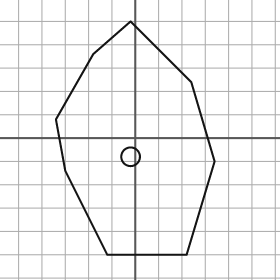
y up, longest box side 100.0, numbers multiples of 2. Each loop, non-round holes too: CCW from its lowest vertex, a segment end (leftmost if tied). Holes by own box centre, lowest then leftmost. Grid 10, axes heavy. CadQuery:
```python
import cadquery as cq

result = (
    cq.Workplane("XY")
    .moveTo(-12.0, -50.0)
    .lineTo(22.0, -50.0)
    .lineTo(34.0, -10.0)
    .lineTo(24.0, 24.0)
    .lineTo(-2.0, 50.0)
    .lineTo(-18.0, 36.0)
    .lineTo(-34.0, 8.0)
    .lineTo(-30.0, -14.0)
    .close()
    .moveTo(-2.0, -8.0)
    .circle(4.0)
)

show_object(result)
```